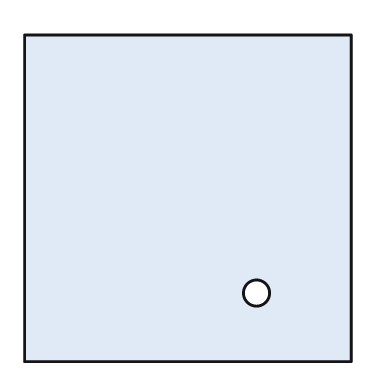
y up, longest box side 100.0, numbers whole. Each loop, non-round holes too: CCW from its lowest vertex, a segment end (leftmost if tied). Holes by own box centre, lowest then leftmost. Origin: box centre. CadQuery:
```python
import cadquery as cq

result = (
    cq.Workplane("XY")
    .moveTo(-50.0, -50.0)
    .lineTo(50.0, -50.0)
    .lineTo(50.0, 50.0)
    .lineTo(-50.0, 50.0)
    .close()
    .moveTo(21.0, -29.0)
    .circle(4.0)
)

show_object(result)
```